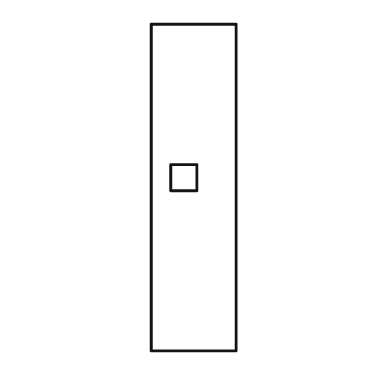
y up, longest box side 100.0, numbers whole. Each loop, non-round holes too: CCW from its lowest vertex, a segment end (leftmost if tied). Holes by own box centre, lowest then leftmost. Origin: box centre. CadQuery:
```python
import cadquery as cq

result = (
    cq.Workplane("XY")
    .moveTo(-13.0, -50.0)
    .lineTo(13.0, -50.0)
    .lineTo(13.0, 50.0)
    .lineTo(-13.0, 50.0)
    .close()
    .moveTo(-7.0, -1.0)
    .lineTo(1.0, -1.0)
    .lineTo(1.0, 7.0)
    .lineTo(-7.0, 7.0)
    .close()
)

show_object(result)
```